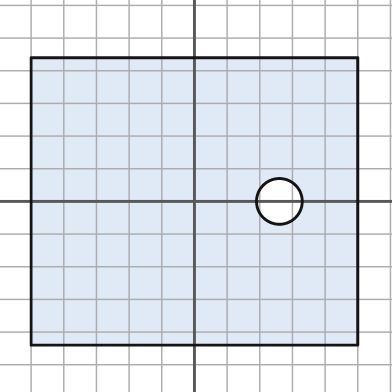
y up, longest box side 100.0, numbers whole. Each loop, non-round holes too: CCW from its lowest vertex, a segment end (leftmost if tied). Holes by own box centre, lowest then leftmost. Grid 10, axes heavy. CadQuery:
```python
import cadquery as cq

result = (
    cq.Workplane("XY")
    .moveTo(-50.0, -44.0)
    .lineTo(50.0, -44.0)
    .lineTo(50.0, 44.0)
    .lineTo(-50.0, 44.0)
    .close()
    .moveTo(26.0, 0.0)
    .circle(7.0)
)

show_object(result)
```